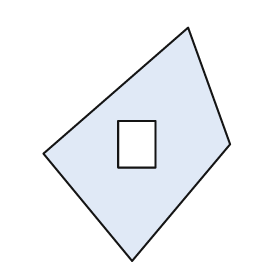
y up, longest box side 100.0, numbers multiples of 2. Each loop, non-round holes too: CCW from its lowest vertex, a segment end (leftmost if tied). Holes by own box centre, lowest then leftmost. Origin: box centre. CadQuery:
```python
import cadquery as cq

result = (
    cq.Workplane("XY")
    .moveTo(-2.0, -50.0)
    .lineTo(40.0, 0.0)
    .lineTo(22.0, 50.0)
    .lineTo(-40.0, -4.0)
    .close()
    .moveTo(-8.0, -10.0)
    .lineTo(8.0, -10.0)
    .lineTo(8.0, 10.0)
    .lineTo(-8.0, 10.0)
    .close()
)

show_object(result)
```